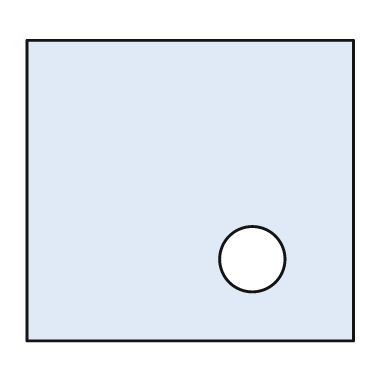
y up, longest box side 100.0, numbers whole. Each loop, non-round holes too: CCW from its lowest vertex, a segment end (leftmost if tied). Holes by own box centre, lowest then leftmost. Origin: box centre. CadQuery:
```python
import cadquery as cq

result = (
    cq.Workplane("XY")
    .moveTo(-50.0, -46.0)
    .lineTo(50.0, -46.0)
    .lineTo(50.0, 46.0)
    .lineTo(-50.0, 46.0)
    .close()
    .moveTo(19.0, -21.0)
    .circle(10.0)
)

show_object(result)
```